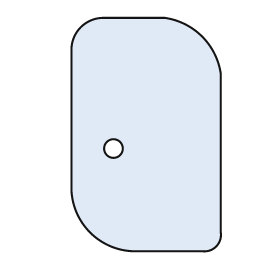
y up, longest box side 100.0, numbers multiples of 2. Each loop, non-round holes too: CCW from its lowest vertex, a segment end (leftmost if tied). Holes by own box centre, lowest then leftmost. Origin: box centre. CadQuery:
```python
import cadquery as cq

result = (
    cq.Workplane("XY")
    .moveTo(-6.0, -50.0)
    .lineTo(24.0, -50.0)
    .threePointArc((30.0, -48.0), (32.0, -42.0))
    .lineTo(32.0, 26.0)
    .threePointArc((24.0, 42.0), (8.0, 50.0))
    .lineTo(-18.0, 50.0)
    .threePointArc((-28.0, 46.0), (-32.0, 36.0))
    .lineTo(-32.0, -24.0)
    .threePointArc((-24.0, -42.0), (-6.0, -50.0))
    .close()
    .moveTo(-14.0, -6.0)
    .circle(4.0)
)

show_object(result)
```